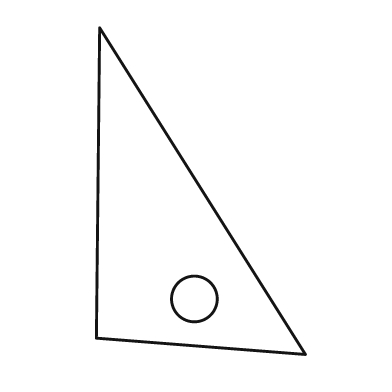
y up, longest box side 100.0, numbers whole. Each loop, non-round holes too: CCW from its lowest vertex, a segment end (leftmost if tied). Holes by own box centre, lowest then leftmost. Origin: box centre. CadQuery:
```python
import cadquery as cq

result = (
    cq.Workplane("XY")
    .moveTo(32.0, -50.0)
    .lineTo(-31.0, 50.0)
    .lineTo(-32.0, -45.0)
    .close()
    .moveTo(-2.0, -33.0)
    .circle(7.0)
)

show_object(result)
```